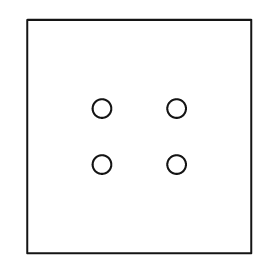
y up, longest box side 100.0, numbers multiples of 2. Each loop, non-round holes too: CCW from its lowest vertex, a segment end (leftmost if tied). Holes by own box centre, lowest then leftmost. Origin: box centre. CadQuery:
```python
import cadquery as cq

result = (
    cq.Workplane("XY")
    .moveTo(-48.0, -50.0)
    .lineTo(48.0, -50.0)
    .lineTo(48.0, 50.0)
    .lineTo(-48.0, 50.0)
    .close()
    .moveTo(-16.0, -12.0)
    .circle(4.0)
    .moveTo(16.0, -12.0)
    .circle(4.0)
    .moveTo(-16.0, 12.0)
    .circle(4.0)
    .moveTo(16.0, 12.0)
    .circle(4.0)
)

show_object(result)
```